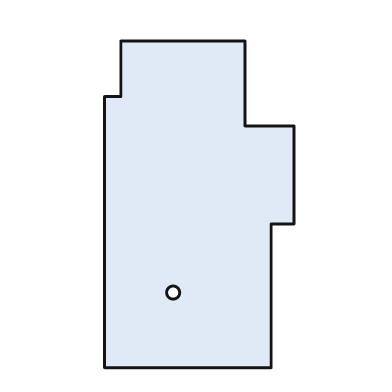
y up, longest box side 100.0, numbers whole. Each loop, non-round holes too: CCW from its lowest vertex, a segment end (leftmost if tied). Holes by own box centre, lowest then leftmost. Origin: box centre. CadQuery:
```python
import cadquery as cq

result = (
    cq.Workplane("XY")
    .moveTo(-29.0, -50.0)
    .lineTo(22.0, -50.0)
    .lineTo(22.0, -6.0)
    .lineTo(29.0, -6.0)
    .lineTo(29.0, 24.0)
    .lineTo(14.0, 24.0)
    .lineTo(14.0, 50.0)
    .lineTo(-24.0, 50.0)
    .lineTo(-24.0, 33.0)
    .lineTo(-29.0, 33.0)
    .close()
    .moveTo(-8.0, -27.0)
    .circle(2.0)
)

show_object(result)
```